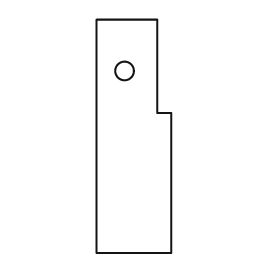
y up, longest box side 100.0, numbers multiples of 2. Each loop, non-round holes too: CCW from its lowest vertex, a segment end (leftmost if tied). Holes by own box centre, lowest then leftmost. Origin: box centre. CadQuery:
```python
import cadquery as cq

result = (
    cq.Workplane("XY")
    .moveTo(-16.0, -50.0)
    .lineTo(16.0, -50.0)
    .lineTo(16.0, 10.0)
    .lineTo(10.0, 10.0)
    .lineTo(10.0, 50.0)
    .lineTo(-16.0, 50.0)
    .close()
    .moveTo(-4.0, 28.0)
    .circle(4.0)
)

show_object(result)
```